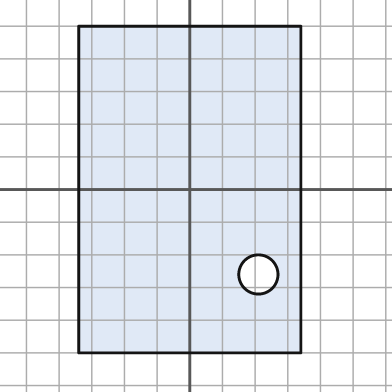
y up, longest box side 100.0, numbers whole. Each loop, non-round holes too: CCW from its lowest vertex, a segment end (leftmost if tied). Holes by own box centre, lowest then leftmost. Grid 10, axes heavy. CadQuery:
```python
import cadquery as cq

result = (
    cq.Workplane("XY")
    .moveTo(-34.0, -50.0)
    .lineTo(34.0, -50.0)
    .lineTo(34.0, 50.0)
    .lineTo(-34.0, 50.0)
    .close()
    .moveTo(21.0, -26.0)
    .circle(6.0)
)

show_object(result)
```